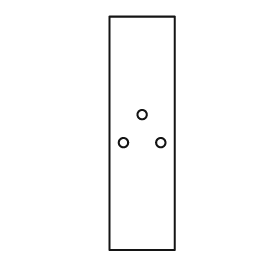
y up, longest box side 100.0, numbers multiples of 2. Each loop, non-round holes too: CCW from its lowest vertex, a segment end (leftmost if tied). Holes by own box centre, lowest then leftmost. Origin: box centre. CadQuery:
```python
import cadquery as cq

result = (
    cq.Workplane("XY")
    .moveTo(-14.0, -50.0)
    .lineTo(14.0, -50.0)
    .lineTo(14.0, 50.0)
    .lineTo(-14.0, 50.0)
    .close()
    .moveTo(-8.0, -4.0)
    .circle(2.0)
    .moveTo(8.0, -4.0)
    .circle(2.0)
    .moveTo(0.0, 8.0)
    .circle(2.0)
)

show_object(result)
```